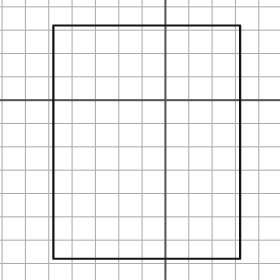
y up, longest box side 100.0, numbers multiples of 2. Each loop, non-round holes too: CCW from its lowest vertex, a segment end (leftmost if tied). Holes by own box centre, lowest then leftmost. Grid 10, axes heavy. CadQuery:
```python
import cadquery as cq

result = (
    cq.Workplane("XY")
    .moveTo(-48.0, -68.0)
    .lineTo(32.0, -68.0)
    .lineTo(32.0, 32.0)
    .lineTo(-48.0, 32.0)
    .close()
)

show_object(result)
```